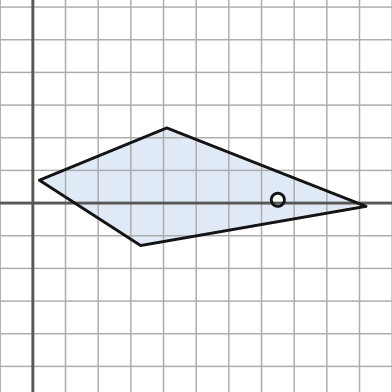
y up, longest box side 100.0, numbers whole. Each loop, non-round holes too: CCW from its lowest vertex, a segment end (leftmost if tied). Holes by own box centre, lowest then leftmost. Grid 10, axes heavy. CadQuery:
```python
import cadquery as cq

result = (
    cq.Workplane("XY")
    .moveTo(33.0, -13.0)
    .lineTo(102.0, -1.0)
    .lineTo(41.0, 23.0)
    .lineTo(2.0, 7.0)
    .close()
    .moveTo(75.0, 1.0)
    .circle(2.0)
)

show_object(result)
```